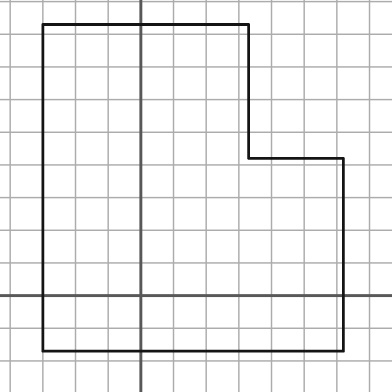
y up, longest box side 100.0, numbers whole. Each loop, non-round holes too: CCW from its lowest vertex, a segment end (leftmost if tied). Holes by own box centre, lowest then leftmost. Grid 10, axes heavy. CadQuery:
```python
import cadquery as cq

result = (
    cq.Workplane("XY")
    .moveTo(-30.0, -17.0)
    .lineTo(62.0, -17.0)
    .lineTo(62.0, 42.0)
    .lineTo(33.0, 42.0)
    .lineTo(33.0, 83.0)
    .lineTo(-30.0, 83.0)
    .close()
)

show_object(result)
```